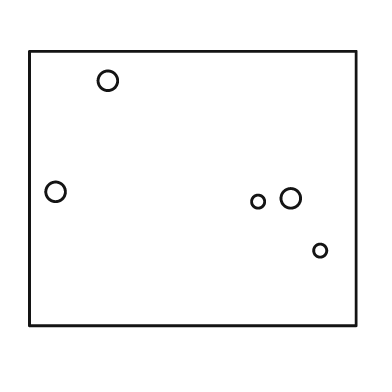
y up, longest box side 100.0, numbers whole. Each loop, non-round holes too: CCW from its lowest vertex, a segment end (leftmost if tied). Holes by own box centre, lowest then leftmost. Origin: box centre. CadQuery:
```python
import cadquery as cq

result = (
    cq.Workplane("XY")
    .moveTo(-50.0, -42.0)
    .lineTo(50.0, -42.0)
    .lineTo(50.0, 42.0)
    .lineTo(-50.0, 42.0)
    .close()
    .moveTo(39.0, -19.0)
    .circle(2.0)
    .moveTo(20.0, -4.0)
    .circle(2.0)
    .moveTo(30.0, -3.0)
    .circle(3.0)
    .moveTo(-42.0, -1.0)
    .circle(3.0)
    .moveTo(-26.0, 33.0)
    .circle(3.0)
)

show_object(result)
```